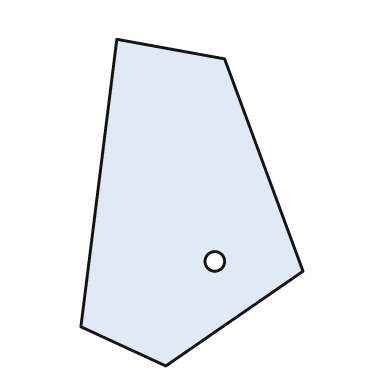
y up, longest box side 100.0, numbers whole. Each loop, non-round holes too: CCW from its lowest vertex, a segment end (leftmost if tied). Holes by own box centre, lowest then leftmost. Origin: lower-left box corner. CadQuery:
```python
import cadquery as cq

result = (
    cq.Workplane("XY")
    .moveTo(26.0, 0.0)
    .lineTo(68.0, 29.0)
    .lineTo(44.0, 94.0)
    .lineTo(11.0, 100.0)
    .lineTo(0.0, 12.0)
    .close()
    .moveTo(41.0, 32.0)
    .circle(3.0)
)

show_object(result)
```